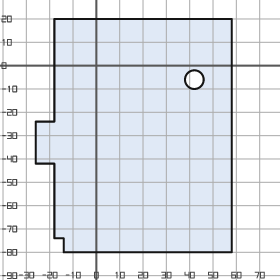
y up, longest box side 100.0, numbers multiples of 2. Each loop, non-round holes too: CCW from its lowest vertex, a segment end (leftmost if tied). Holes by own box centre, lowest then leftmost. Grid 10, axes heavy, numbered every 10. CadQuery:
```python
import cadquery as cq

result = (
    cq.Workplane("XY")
    .moveTo(-14.0, -80.0)
    .lineTo(58.0, -80.0)
    .lineTo(58.0, 20.0)
    .lineTo(-18.0, 20.0)
    .lineTo(-18.0, -24.0)
    .lineTo(-26.0, -24.0)
    .lineTo(-26.0, -42.0)
    .lineTo(-18.0, -42.0)
    .lineTo(-18.0, -74.0)
    .lineTo(-14.0, -74.0)
    .close()
    .moveTo(42.0, -6.0)
    .circle(4.0)
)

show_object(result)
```